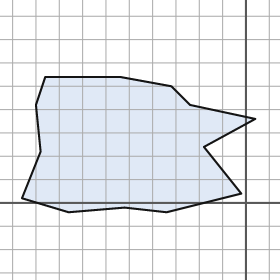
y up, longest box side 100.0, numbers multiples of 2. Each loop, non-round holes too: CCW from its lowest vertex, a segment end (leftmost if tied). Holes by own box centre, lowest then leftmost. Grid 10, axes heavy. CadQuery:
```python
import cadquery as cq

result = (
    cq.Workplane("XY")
    .moveTo(-76.0, -4.0)
    .lineTo(-52.0, -2.0)
    .lineTo(-34.0, -4.0)
    .lineTo(-2.0, 4.0)
    .lineTo(-18.0, 24.0)
    .lineTo(4.0, 36.0)
    .lineTo(-24.0, 42.0)
    .lineTo(-32.0, 50.0)
    .lineTo(-54.0, 54.0)
    .lineTo(-86.0, 54.0)
    .lineTo(-90.0, 42.0)
    .lineTo(-88.0, 22.0)
    .lineTo(-96.0, 2.0)
    .close()
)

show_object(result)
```